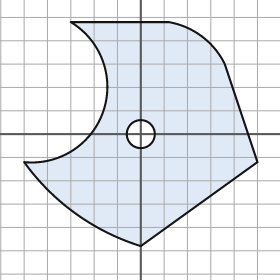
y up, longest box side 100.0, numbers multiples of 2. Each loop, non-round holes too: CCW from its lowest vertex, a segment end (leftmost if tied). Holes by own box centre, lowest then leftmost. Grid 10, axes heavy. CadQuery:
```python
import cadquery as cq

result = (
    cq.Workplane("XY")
    .moveTo(0.0, -48.0)
    .lineTo(50.0, -12.0)
    .lineTo(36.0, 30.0)
    .threePointArc((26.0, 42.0), (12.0, 48.0))
    .lineTo(-30.0, 48.0)
    .threePointArc((-16.0, 10.0), (-50.0, -12.0))
    .threePointArc((-28.0, -34.0), (0.0, -48.0))
    .close()
    .moveTo(0.0, 0.0)
    .circle(6.0)
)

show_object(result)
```